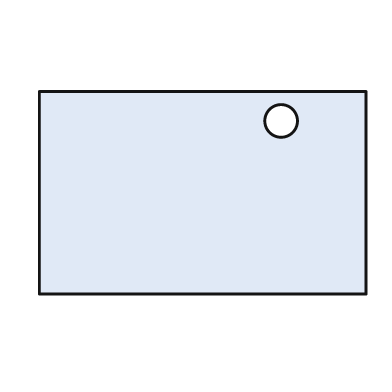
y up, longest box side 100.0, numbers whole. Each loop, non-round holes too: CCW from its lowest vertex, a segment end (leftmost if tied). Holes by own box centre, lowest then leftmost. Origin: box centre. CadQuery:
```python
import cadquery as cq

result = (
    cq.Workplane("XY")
    .moveTo(-50.0, -31.0)
    .lineTo(50.0, -31.0)
    .lineTo(50.0, 31.0)
    .lineTo(-50.0, 31.0)
    .close()
    .moveTo(24.0, 22.0)
    .circle(5.0)
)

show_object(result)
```